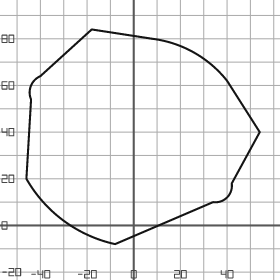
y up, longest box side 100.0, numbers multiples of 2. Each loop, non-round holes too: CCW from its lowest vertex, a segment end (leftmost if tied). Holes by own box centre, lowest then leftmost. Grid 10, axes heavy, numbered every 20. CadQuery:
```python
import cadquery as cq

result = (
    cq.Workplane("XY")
    .moveTo(-8.0, -8.0)
    .lineTo(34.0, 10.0)
    .threePointArc((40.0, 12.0), (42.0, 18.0))
    .lineTo(54.0, 40.0)
    .lineTo(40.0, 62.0)
    .threePointArc((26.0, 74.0), (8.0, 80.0))
    .lineTo(-18.0, 84.0)
    .lineTo(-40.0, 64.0)
    .threePointArc((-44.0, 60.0), (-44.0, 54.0))
    .lineTo(-46.0, 20.0)
    .threePointArc((-30.0, 2.0), (-8.0, -8.0))
    .close()
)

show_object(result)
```